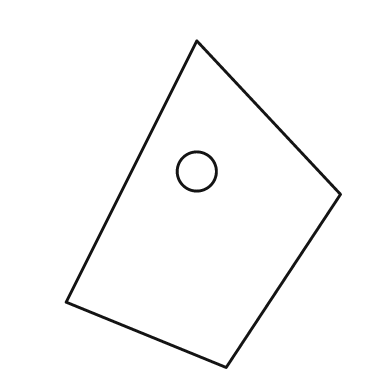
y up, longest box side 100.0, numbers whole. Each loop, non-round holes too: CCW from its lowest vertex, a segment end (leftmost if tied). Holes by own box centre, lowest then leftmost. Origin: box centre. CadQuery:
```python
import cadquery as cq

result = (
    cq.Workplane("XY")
    .moveTo(7.0, -50.0)
    .lineTo(42.0, 3.0)
    .lineTo(-2.0, 50.0)
    .lineTo(-42.0, -30.0)
    .close()
    .moveTo(-2.0, 10.0)
    .circle(6.0)
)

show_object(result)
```